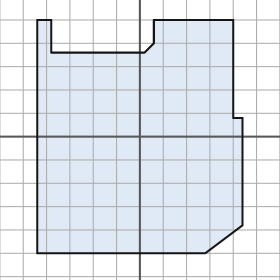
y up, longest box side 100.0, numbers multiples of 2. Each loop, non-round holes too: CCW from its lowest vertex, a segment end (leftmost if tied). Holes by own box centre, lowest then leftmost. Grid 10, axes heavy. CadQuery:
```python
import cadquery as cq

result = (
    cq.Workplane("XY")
    .moveTo(-44.0, -50.0)
    .lineTo(28.0, -50.0)
    .lineTo(44.0, -38.0)
    .lineTo(44.0, 8.0)
    .lineTo(40.0, 8.0)
    .lineTo(40.0, 50.0)
    .lineTo(6.0, 50.0)
    .lineTo(6.0, 40.0)
    .lineTo(2.0, 36.0)
    .lineTo(-38.0, 36.0)
    .lineTo(-38.0, 50.0)
    .lineTo(-44.0, 50.0)
    .close()
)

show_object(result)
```